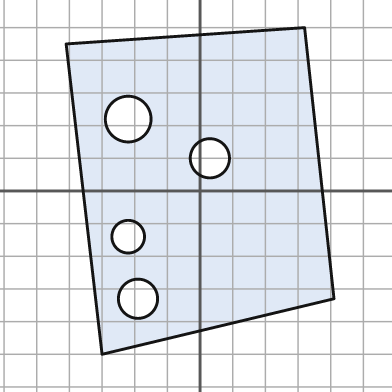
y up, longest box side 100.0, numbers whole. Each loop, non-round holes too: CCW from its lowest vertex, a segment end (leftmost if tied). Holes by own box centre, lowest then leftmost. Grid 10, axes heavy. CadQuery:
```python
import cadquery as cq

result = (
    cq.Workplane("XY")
    .moveTo(-30.0, -50.0)
    .lineTo(41.0, -33.0)
    .lineTo(32.0, 50.0)
    .lineTo(-41.0, 45.0)
    .close()
    .moveTo(-19.0, -33.0)
    .circle(6.0)
    .moveTo(-22.0, -14.0)
    .circle(5.0)
    .moveTo(3.0, 10.0)
    .circle(6.0)
    .moveTo(-22.0, 22.0)
    .circle(7.0)
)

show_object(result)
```